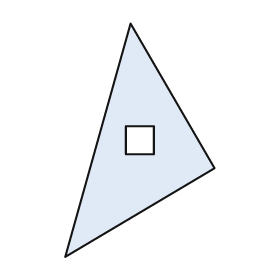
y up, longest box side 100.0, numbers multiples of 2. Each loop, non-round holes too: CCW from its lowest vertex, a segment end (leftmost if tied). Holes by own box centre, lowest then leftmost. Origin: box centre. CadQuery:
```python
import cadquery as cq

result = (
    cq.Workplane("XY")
    .moveTo(-32.0, -50.0)
    .lineTo(32.0, -12.0)
    .lineTo(-4.0, 50.0)
    .close()
    .moveTo(-6.0, -6.0)
    .lineTo(6.0, -6.0)
    .lineTo(6.0, 6.0)
    .lineTo(-6.0, 6.0)
    .close()
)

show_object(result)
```